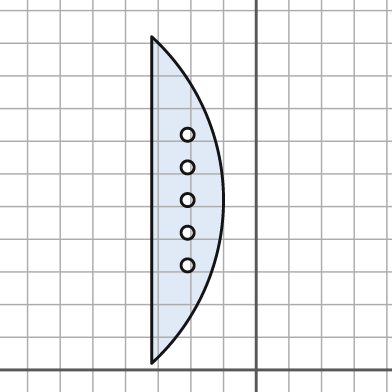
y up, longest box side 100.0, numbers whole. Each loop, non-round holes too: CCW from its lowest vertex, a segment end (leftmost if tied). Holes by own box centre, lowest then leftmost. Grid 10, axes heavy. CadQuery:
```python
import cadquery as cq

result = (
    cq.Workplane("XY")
    .moveTo(-32.0, 2.0)
    .threePointArc((-10.0, 52.0), (-32.0, 102.0))
    .close()
    .moveTo(-21.0, 32.0)
    .circle(2.0)
    .moveTo(-21.0, 42.0)
    .circle(2.0)
    .moveTo(-21.0, 52.0)
    .circle(2.0)
    .moveTo(-21.0, 62.0)
    .circle(2.0)
    .moveTo(-21.0, 72.0)
    .circle(2.0)
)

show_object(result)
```